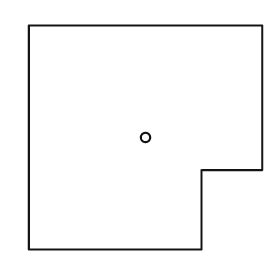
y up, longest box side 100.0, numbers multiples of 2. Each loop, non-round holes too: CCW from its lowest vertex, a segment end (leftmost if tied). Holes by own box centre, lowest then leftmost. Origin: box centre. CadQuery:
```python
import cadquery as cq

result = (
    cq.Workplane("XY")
    .moveTo(-50.0, -48.0)
    .lineTo(24.0, -48.0)
    .lineTo(24.0, -14.0)
    .lineTo(50.0, -14.0)
    .lineTo(50.0, 48.0)
    .lineTo(-50.0, 48.0)
    .close()
    .moveTo(0.0, 0.0)
    .circle(2.0)
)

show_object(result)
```